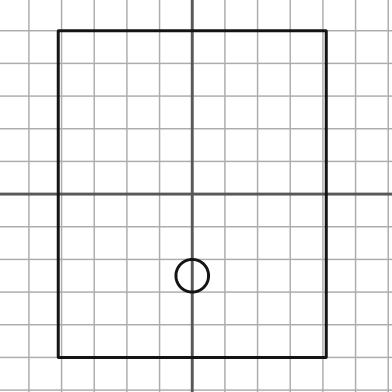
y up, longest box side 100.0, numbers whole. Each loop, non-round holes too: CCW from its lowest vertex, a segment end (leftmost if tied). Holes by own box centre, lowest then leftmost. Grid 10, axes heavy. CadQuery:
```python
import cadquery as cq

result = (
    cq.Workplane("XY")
    .moveTo(-41.0, -50.0)
    .lineTo(41.0, -50.0)
    .lineTo(41.0, 50.0)
    .lineTo(-41.0, 50.0)
    .close()
    .moveTo(0.0, -25.0)
    .circle(5.0)
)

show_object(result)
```